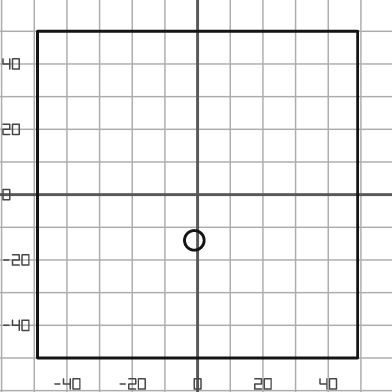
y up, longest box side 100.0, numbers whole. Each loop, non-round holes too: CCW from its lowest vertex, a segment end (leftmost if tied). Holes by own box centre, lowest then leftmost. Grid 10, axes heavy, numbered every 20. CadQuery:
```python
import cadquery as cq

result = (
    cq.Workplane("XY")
    .moveTo(-49.0, -50.0)
    .lineTo(49.0, -50.0)
    .lineTo(49.0, 50.0)
    .lineTo(-49.0, 50.0)
    .close()
    .moveTo(-1.0, -14.0)
    .circle(3.0)
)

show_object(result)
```